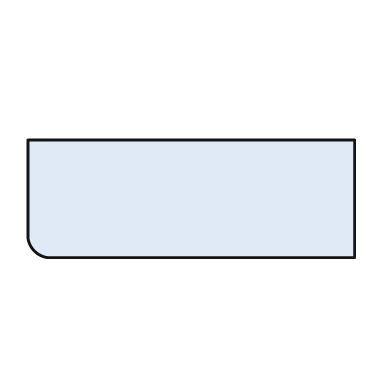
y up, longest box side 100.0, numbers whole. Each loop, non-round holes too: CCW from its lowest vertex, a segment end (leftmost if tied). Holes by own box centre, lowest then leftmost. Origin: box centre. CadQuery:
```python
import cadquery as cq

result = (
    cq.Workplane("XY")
    .moveTo(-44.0, -18.0)
    .lineTo(50.0, -18.0)
    .lineTo(50.0, 18.0)
    .lineTo(-50.0, 18.0)
    .lineTo(-50.0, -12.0)
    .threePointArc((-48.0, -16.0), (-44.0, -18.0))
    .close()
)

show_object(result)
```